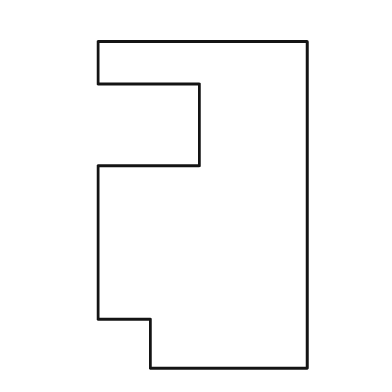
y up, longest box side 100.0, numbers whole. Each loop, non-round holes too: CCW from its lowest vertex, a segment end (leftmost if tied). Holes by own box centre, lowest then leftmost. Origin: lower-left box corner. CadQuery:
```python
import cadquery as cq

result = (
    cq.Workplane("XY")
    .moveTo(16.0, 0.0)
    .lineTo(64.0, 0.0)
    .lineTo(64.0, 100.0)
    .lineTo(0.0, 100.0)
    .lineTo(0.0, 87.0)
    .lineTo(31.0, 87.0)
    .lineTo(31.0, 62.0)
    .lineTo(0.0, 62.0)
    .lineTo(0.0, 15.0)
    .lineTo(16.0, 15.0)
    .close()
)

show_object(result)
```